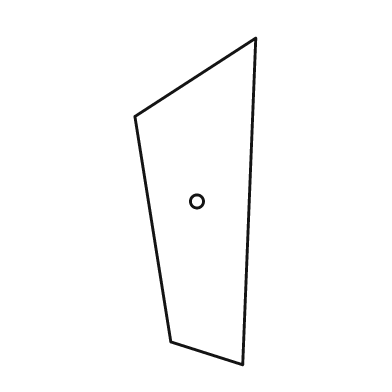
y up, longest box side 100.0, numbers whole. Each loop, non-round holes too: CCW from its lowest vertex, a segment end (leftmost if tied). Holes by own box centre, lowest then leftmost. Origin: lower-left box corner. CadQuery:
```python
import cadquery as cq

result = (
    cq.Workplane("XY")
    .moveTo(33.0, 0.0)
    .lineTo(37.0, 100.0)
    .lineTo(0.0, 76.0)
    .lineTo(11.0, 7.0)
    .close()
    .moveTo(19.0, 50.0)
    .circle(2.0)
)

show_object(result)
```